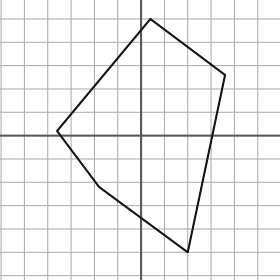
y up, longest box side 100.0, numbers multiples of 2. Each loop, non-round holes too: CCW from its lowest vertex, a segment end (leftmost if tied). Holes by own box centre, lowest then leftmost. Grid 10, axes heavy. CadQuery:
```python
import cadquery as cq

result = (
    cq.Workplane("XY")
    .moveTo(20.0, -50.0)
    .lineTo(36.0, 26.0)
    .lineTo(4.0, 50.0)
    .lineTo(-36.0, 2.0)
    .lineTo(-18.0, -22.0)
    .close()
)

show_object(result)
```